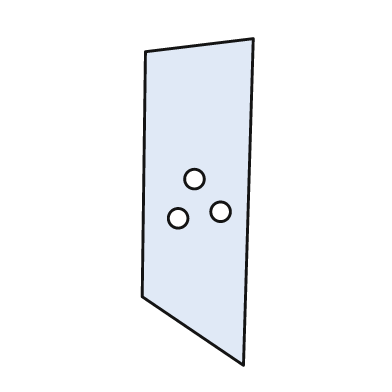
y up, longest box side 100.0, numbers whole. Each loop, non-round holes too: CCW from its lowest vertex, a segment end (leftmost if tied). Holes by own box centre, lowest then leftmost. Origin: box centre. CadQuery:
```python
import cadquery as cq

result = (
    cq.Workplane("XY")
    .moveTo(14.0, -50.0)
    .lineTo(17.0, 50.0)
    .lineTo(-16.0, 46.0)
    .lineTo(-17.0, -29.0)
    .close()
    .moveTo(-6.0, -5.0)
    .circle(3.0)
    .moveTo(7.0, -3.0)
    .circle(3.0)
    .moveTo(-1.0, 7.0)
    .circle(3.0)
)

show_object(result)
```